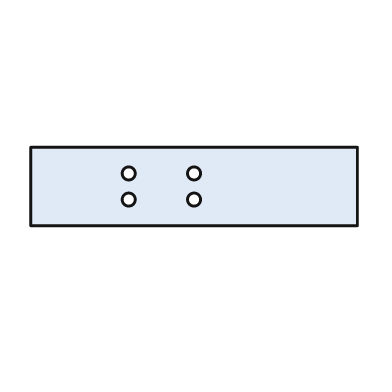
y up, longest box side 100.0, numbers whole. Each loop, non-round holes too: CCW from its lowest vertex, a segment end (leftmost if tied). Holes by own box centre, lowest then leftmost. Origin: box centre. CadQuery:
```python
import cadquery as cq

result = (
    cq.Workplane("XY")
    .moveTo(-50.0, -12.0)
    .lineTo(50.0, -12.0)
    .lineTo(50.0, 12.0)
    .lineTo(-50.0, 12.0)
    .close()
    .moveTo(-20.0, -4.0)
    .circle(2.0)
    .moveTo(0.0, -4.0)
    .circle(2.0)
    .moveTo(-20.0, 4.0)
    .circle(2.0)
    .moveTo(0.0, 4.0)
    .circle(2.0)
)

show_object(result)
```